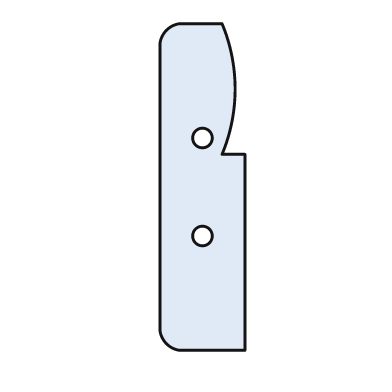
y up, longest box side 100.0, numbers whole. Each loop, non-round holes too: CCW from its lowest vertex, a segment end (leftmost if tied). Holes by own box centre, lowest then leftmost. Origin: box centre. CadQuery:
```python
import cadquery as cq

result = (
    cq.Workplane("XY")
    .moveTo(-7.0, -50.0)
    .lineTo(13.0, -50.0)
    .lineTo(13.0, 10.0)
    .lineTo(6.0, 10.0)
    .threePointArc((10.0, 30.0), (6.0, 50.0))
    .lineTo(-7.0, 50.0)
    .threePointArc((-11.0, 48.0), (-13.0, 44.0))
    .lineTo(-13.0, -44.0)
    .threePointArc((-11.0, -48.0), (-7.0, -50.0))
    .close()
    .moveTo(0.0, -15.0)
    .circle(3.0)
    .moveTo(0.0, 15.0)
    .circle(3.0)
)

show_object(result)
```